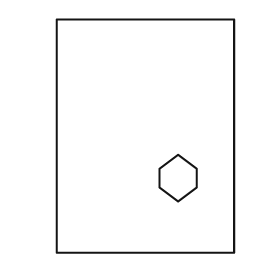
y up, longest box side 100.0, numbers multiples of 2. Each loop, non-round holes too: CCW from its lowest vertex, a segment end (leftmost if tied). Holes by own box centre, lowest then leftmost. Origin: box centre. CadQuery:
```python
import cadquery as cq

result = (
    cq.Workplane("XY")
    .moveTo(-38.0, -50.0)
    .lineTo(38.0, -50.0)
    .lineTo(38.0, 50.0)
    .lineTo(-38.0, 50.0)
    .close()
    .moveTo(14.0, -28.0)
    .lineTo(22.0, -22.0)
    .lineTo(22.0, -14.0)
    .lineTo(14.0, -8.0)
    .lineTo(6.0, -14.0)
    .lineTo(6.0, -22.0)
    .close()
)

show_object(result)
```